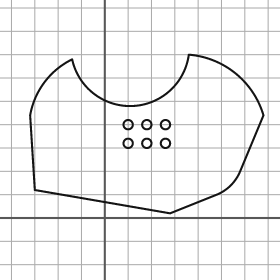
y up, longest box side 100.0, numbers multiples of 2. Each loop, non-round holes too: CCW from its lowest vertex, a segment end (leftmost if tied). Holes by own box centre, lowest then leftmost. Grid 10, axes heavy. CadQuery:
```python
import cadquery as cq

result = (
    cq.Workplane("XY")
    .moveTo(28.0, 2.0)
    .lineTo(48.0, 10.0)
    .threePointArc((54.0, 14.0), (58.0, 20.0))
    .lineTo(68.0, 44.0)
    .threePointArc((56.0, 62.0), (36.0, 70.0))
    .threePointArc((12.0, 48.0), (-14.0, 68.0))
    .threePointArc((-26.0, 58.0), (-32.0, 44.0))
    .lineTo(-30.0, 12.0)
    .close()
    .moveTo(10.0, 32.0)
    .circle(2.0)
    .moveTo(18.0, 32.0)
    .circle(2.0)
    .moveTo(26.0, 32.0)
    .circle(2.0)
    .moveTo(10.0, 40.0)
    .circle(2.0)
    .moveTo(18.0, 40.0)
    .circle(2.0)
    .moveTo(26.0, 40.0)
    .circle(2.0)
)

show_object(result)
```